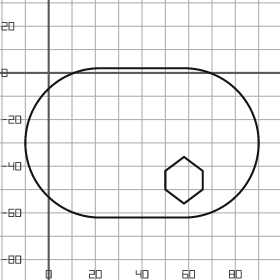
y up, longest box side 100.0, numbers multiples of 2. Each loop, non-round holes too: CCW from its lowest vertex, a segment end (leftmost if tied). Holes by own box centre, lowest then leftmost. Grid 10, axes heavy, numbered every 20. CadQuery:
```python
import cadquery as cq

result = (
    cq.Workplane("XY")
    .moveTo(22.0, -62.0)
    .lineTo(58.0, -62.0)
    .threePointArc((90.0, -30.0), (58.0, 2.0))
    .lineTo(22.0, 2.0)
    .threePointArc((-10.0, -30.0), (22.0, -62.0))
    .close()
    .moveTo(58.0, -56.0)
    .lineTo(66.0, -50.0)
    .lineTo(66.0, -42.0)
    .lineTo(58.0, -36.0)
    .lineTo(50.0, -42.0)
    .lineTo(50.0, -50.0)
    .close()
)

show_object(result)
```